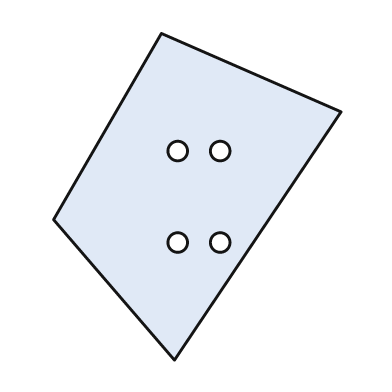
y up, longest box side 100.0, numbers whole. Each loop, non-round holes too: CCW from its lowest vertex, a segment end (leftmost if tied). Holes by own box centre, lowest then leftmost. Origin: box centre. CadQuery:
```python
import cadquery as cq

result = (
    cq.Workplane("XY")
    .moveTo(-7.0, -50.0)
    .lineTo(44.0, 26.0)
    .lineTo(-11.0, 50.0)
    .lineTo(-44.0, -7.0)
    .close()
    .moveTo(-6.0, -14.0)
    .circle(3.0)
    .moveTo(7.0, -14.0)
    .circle(3.0)
    .moveTo(-6.0, 14.0)
    .circle(3.0)
    .moveTo(7.0, 14.0)
    .circle(3.0)
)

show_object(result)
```